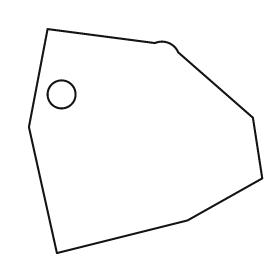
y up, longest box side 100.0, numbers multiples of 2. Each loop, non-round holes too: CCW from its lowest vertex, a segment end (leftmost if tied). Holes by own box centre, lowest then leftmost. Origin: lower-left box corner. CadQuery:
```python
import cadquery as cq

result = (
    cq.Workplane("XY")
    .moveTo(12.0, 0.0)
    .lineTo(68.0, 14.0)
    .lineTo(100.0, 32.0)
    .lineTo(96.0, 58.0)
    .lineTo(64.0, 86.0)
    .threePointArc((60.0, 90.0), (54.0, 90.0))
    .lineTo(8.0, 96.0)
    .lineTo(0.0, 54.0)
    .close()
    .moveTo(14.0, 68.0)
    .circle(6.0)
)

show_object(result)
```